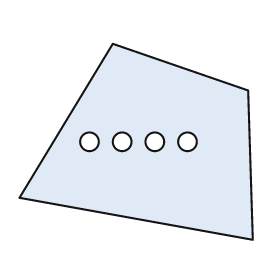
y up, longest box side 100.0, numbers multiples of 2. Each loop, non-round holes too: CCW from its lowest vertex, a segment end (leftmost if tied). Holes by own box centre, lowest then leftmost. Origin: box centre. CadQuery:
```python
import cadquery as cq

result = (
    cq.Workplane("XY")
    .moveTo(50.0, -42.0)
    .lineTo(48.0, 22.0)
    .lineTo(-10.0, 42.0)
    .lineTo(-50.0, -24.0)
    .close()
    .moveTo(-20.0, 0.0)
    .circle(4.0)
    .moveTo(-6.0, 0.0)
    .circle(4.0)
    .moveTo(8.0, 0.0)
    .circle(4.0)
    .moveTo(22.0, 0.0)
    .circle(4.0)
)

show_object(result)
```